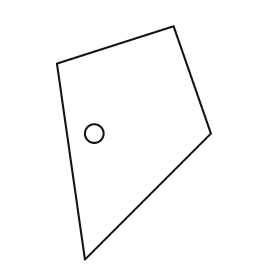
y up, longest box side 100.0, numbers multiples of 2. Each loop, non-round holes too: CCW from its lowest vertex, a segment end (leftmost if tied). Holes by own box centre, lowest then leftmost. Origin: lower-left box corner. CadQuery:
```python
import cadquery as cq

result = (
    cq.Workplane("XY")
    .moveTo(12.0, 0.0)
    .lineTo(66.0, 54.0)
    .lineTo(50.0, 100.0)
    .lineTo(0.0, 84.0)
    .close()
    .moveTo(16.0, 54.0)
    .circle(4.0)
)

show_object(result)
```